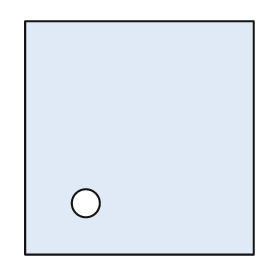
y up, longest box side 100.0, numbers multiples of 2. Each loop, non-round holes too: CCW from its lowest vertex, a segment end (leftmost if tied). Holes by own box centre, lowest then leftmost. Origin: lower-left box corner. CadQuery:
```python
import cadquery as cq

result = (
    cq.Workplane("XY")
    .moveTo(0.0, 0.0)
    .lineTo(98.0, 0.0)
    .lineTo(98.0, 100.0)
    .lineTo(0.0, 100.0)
    .close()
    .moveTo(26.0, 22.0)
    .circle(6.0)
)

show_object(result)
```